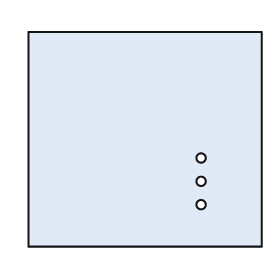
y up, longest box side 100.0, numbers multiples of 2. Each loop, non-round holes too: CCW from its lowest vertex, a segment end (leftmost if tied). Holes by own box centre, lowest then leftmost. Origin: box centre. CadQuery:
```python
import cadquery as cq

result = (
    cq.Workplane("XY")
    .moveTo(-50.0, -46.0)
    .lineTo(50.0, -46.0)
    .lineTo(50.0, 46.0)
    .lineTo(-50.0, 46.0)
    .close()
    .moveTo(24.0, -28.0)
    .circle(2.0)
    .moveTo(24.0, -18.0)
    .circle(2.0)
    .moveTo(24.0, -8.0)
    .circle(2.0)
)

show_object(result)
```